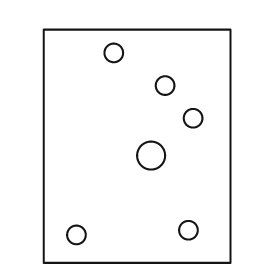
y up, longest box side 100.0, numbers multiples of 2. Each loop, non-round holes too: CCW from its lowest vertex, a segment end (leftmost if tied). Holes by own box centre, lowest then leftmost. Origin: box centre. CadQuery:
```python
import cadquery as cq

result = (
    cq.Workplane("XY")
    .moveTo(-40.0, -50.0)
    .lineTo(40.0, -50.0)
    .lineTo(40.0, 50.0)
    .lineTo(-40.0, 50.0)
    .close()
    .moveTo(-26.0, -38.0)
    .circle(4.0)
    .moveTo(22.0, -36.0)
    .circle(4.0)
    .moveTo(6.0, -4.0)
    .circle(6.0)
    .moveTo(24.0, 12.0)
    .circle(4.0)
    .moveTo(12.0, 26.0)
    .circle(4.0)
    .moveTo(-10.0, 40.0)
    .circle(4.0)
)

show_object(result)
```